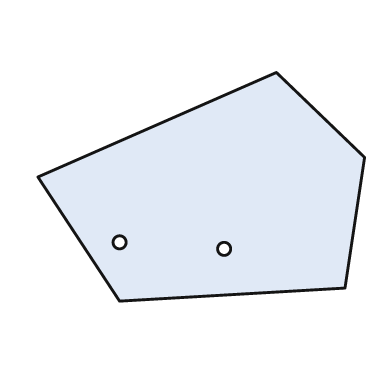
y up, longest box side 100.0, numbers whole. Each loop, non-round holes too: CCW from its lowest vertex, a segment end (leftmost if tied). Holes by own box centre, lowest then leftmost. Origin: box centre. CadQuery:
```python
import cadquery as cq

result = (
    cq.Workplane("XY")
    .moveTo(-25.0, -35.0)
    .lineTo(44.0, -31.0)
    .lineTo(50.0, 9.0)
    .lineTo(23.0, 35.0)
    .lineTo(-50.0, 3.0)
    .close()
    .moveTo(7.0, -19.0)
    .circle(2.0)
    .moveTo(-25.0, -17.0)
    .circle(2.0)
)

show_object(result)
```